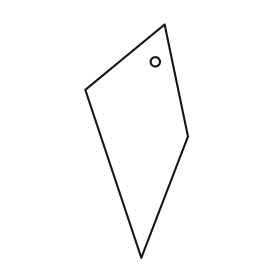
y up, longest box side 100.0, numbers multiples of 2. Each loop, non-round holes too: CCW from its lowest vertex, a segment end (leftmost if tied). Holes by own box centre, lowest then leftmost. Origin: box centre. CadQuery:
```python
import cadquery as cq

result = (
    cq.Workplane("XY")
    .moveTo(2.0, -50.0)
    .lineTo(22.0, 2.0)
    .lineTo(12.0, 50.0)
    .lineTo(-22.0, 22.0)
    .close()
    .moveTo(8.0, 34.0)
    .circle(2.0)
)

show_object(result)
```